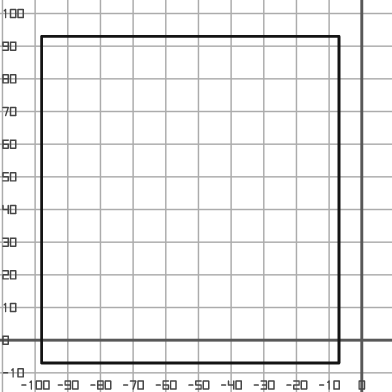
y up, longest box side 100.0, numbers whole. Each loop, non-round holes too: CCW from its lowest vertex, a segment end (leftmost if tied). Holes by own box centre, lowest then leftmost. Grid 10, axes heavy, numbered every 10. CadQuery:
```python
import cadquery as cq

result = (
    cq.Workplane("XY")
    .moveTo(-98.0, -7.0)
    .lineTo(-7.0, -7.0)
    .lineTo(-7.0, 93.0)
    .lineTo(-98.0, 93.0)
    .close()
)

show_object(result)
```